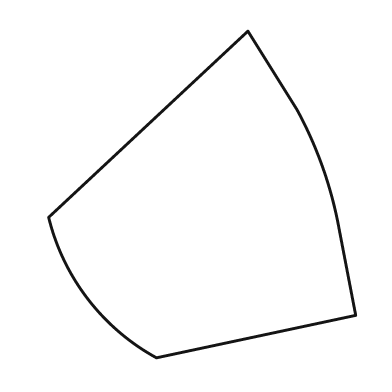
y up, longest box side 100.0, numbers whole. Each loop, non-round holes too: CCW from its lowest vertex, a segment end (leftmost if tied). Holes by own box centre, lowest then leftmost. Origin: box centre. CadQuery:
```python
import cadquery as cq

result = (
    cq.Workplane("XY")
    .moveTo(-14.0, -50.0)
    .lineTo(47.0, -37.0)
    .lineTo(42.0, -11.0)
    .threePointArc((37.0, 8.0), (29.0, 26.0))
    .lineTo(14.0, 50.0)
    .lineTo(-47.0, -7.0)
    .threePointArc((-35.0, -32.0), (-14.0, -50.0))
    .close()
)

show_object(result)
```